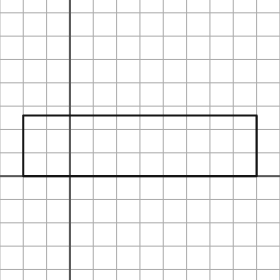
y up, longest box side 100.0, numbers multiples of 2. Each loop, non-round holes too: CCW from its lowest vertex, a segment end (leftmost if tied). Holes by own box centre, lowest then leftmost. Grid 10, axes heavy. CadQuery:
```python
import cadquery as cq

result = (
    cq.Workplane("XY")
    .moveTo(-20.0, 0.0)
    .lineTo(80.0, 0.0)
    .lineTo(80.0, 26.0)
    .lineTo(-20.0, 26.0)
    .close()
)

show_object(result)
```